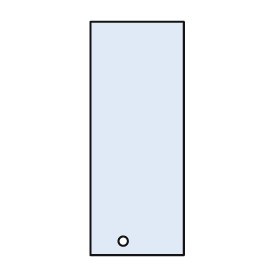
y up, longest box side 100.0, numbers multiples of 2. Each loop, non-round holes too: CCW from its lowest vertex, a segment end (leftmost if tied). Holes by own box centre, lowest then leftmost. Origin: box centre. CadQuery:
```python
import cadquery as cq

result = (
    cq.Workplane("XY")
    .moveTo(-20.0, -50.0)
    .lineTo(20.0, -50.0)
    .lineTo(20.0, 50.0)
    .lineTo(-20.0, 50.0)
    .close()
    .moveTo(-6.0, -44.0)
    .circle(2.0)
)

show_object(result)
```